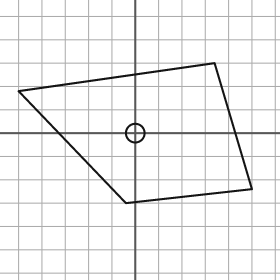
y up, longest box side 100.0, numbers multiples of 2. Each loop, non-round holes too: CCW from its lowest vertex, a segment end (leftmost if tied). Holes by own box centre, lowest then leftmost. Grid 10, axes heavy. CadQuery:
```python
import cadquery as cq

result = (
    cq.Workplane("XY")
    .moveTo(-4.0, -30.0)
    .lineTo(50.0, -24.0)
    .lineTo(34.0, 30.0)
    .lineTo(-50.0, 18.0)
    .close()
    .moveTo(0.0, 0.0)
    .circle(4.0)
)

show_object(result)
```